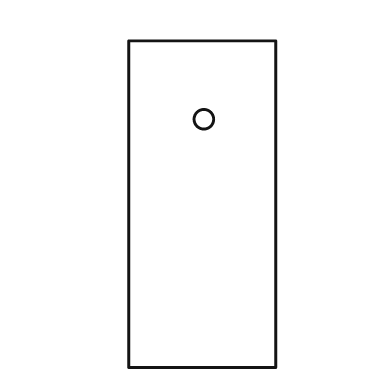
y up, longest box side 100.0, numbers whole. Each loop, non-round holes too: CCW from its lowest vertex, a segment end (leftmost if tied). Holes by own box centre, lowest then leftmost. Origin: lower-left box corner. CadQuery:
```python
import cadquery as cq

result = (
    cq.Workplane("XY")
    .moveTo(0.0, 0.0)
    .lineTo(45.0, 0.0)
    .lineTo(45.0, 100.0)
    .lineTo(0.0, 100.0)
    .close()
    .moveTo(23.0, 76.0)
    .circle(3.0)
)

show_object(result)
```